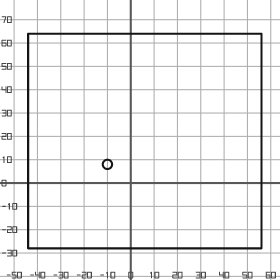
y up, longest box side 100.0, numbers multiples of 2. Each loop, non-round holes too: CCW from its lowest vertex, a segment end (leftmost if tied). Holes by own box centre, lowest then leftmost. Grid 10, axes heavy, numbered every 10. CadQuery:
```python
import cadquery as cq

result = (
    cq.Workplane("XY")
    .moveTo(-44.0, -28.0)
    .lineTo(56.0, -28.0)
    .lineTo(56.0, 64.0)
    .lineTo(-44.0, 64.0)
    .close()
    .moveTo(-10.0, 8.0)
    .circle(2.0)
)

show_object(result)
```